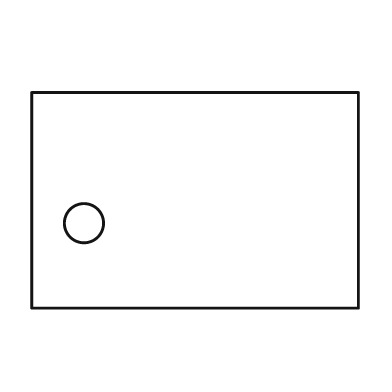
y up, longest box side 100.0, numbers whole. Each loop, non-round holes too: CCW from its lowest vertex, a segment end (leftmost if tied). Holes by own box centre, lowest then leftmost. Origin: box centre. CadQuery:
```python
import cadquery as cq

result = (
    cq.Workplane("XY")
    .moveTo(-50.0, -33.0)
    .lineTo(50.0, -33.0)
    .lineTo(50.0, 33.0)
    .lineTo(-50.0, 33.0)
    .close()
    .moveTo(-34.0, -7.0)
    .circle(6.0)
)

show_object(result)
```